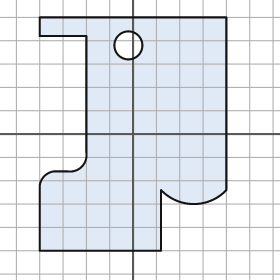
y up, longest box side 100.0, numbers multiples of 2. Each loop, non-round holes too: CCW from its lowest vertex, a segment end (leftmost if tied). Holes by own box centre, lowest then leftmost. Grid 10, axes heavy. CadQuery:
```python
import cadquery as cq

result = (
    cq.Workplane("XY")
    .moveTo(-40.0, -50.0)
    .lineTo(12.0, -50.0)
    .lineTo(12.0, -24.0)
    .threePointArc((26.0, -30.0), (40.0, -24.0))
    .lineTo(40.0, 50.0)
    .lineTo(-40.0, 50.0)
    .lineTo(-40.0, 42.0)
    .lineTo(-20.0, 42.0)
    .lineTo(-20.0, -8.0)
    .threePointArc((-22.0, -14.0), (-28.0, -16.0))
    .lineTo(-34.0, -16.0)
    .threePointArc((-38.0, -18.0), (-40.0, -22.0))
    .close()
    .moveTo(-2.0, 38.0)
    .circle(6.0)
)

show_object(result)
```